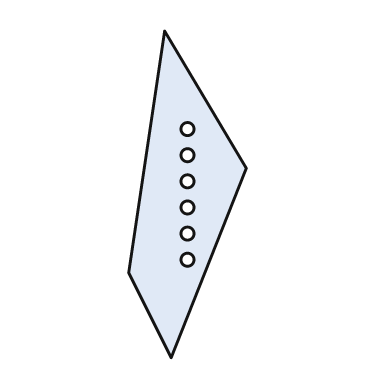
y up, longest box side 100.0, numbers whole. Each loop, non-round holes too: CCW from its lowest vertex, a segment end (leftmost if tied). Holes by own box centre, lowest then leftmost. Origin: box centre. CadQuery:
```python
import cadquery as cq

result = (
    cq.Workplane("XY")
    .moveTo(-5.0, -50.0)
    .lineTo(18.0, 8.0)
    .lineTo(-7.0, 50.0)
    .lineTo(-18.0, -24.0)
    .close()
    .moveTo(0.0, -20.0)
    .circle(2.0)
    .moveTo(0.0, -12.0)
    .circle(2.0)
    .moveTo(0.0, -4.0)
    .circle(2.0)
    .moveTo(0.0, 4.0)
    .circle(2.0)
    .moveTo(0.0, 12.0)
    .circle(2.0)
    .moveTo(0.0, 20.0)
    .circle(2.0)
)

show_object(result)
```